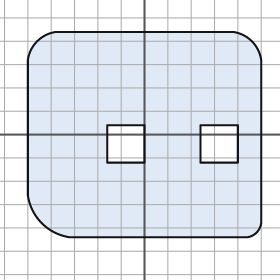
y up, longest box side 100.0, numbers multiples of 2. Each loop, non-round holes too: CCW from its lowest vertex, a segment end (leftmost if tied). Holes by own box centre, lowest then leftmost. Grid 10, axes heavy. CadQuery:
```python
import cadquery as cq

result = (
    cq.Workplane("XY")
    .moveTo(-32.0, -44.0)
    .lineTo(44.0, -44.0)
    .threePointArc((48.0, -42.0), (50.0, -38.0))
    .lineTo(50.0, 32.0)
    .threePointArc((46.0, 40.0), (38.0, 44.0))
    .lineTo(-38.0, 44.0)
    .threePointArc((-46.0, 40.0), (-50.0, 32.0))
    .lineTo(-50.0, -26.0)
    .threePointArc((-44.0, -38.0), (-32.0, -44.0))
    .close()
    .moveTo(-16.0, -12.0)
    .lineTo(0.0, -12.0)
    .lineTo(0.0, 4.0)
    .lineTo(-16.0, 4.0)
    .close()
    .moveTo(24.0, -12.0)
    .lineTo(40.0, -12.0)
    .lineTo(40.0, 4.0)
    .lineTo(24.0, 4.0)
    .close()
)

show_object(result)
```